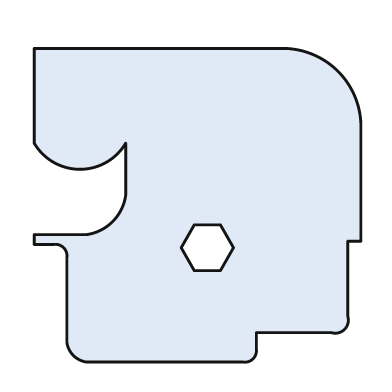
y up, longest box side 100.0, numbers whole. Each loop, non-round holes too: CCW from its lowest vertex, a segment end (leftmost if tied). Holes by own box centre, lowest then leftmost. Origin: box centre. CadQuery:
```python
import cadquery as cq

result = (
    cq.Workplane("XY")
    .moveTo(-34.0, -48.0)
    .lineTo(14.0, -48.0)
    .threePointArc((17.0, -47.0), (18.0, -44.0))
    .lineTo(18.0, -39.0)
    .lineTo(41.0, -39.0)
    .threePointArc((45.0, -38.0), (46.0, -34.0))
    .lineTo(46.0, -11.0)
    .lineTo(50.0, -11.0)
    .lineTo(50.0, 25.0)
    .threePointArc((43.0, 41.0), (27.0, 48.0))
    .lineTo(-50.0, 48.0)
    .lineTo(-50.0, 19.0)
    .threePointArc((-36.0, 11.0), (-22.0, 19.0))
    .lineTo(-22.0, 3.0)
    .threePointArc((-26.0, -5.0), (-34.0, -9.0))
    .lineTo(-50.0, -9.0)
    .lineTo(-50.0, -12.0)
    .lineTo(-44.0, -12.0)
    .threePointArc((-41.0, -13.0), (-40.0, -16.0))
    .lineTo(-40.0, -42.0)
    .threePointArc((-38.0, -46.0), (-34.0, -48.0))
    .close()
    .moveTo(-1.0, -20.0)
    .lineTo(7.0, -20.0)
    .lineTo(11.0, -13.0)
    .lineTo(7.0, -6.0)
    .lineTo(-1.0, -6.0)
    .lineTo(-5.0, -13.0)
    .close()
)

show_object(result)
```